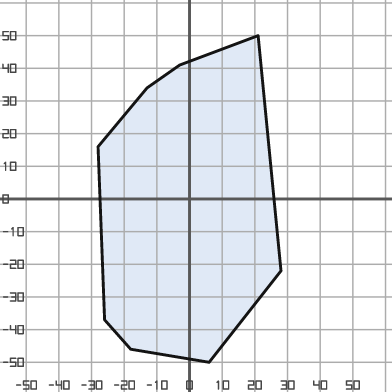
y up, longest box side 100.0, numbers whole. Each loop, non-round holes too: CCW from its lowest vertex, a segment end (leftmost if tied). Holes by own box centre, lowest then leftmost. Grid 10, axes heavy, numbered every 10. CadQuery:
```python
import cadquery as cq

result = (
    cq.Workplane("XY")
    .moveTo(6.0, -50.0)
    .lineTo(28.0, -22.0)
    .lineTo(21.0, 50.0)
    .lineTo(-3.0, 41.0)
    .lineTo(-13.0, 34.0)
    .lineTo(-28.0, 16.0)
    .lineTo(-26.0, -37.0)
    .lineTo(-18.0, -46.0)
    .close()
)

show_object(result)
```